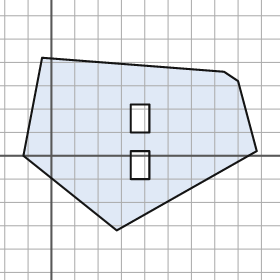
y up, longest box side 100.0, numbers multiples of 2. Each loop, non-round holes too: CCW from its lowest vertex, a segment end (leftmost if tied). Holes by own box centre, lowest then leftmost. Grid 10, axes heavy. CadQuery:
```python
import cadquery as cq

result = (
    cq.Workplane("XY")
    .moveTo(28.0, -32.0)
    .lineTo(88.0, 2.0)
    .lineTo(80.0, 32.0)
    .lineTo(74.0, 36.0)
    .lineTo(-4.0, 42.0)
    .lineTo(-12.0, 0.0)
    .close()
    .moveTo(34.0, -10.0)
    .lineTo(42.0, -10.0)
    .lineTo(42.0, 2.0)
    .lineTo(34.0, 2.0)
    .close()
    .moveTo(34.0, 10.0)
    .lineTo(42.0, 10.0)
    .lineTo(42.0, 22.0)
    .lineTo(34.0, 22.0)
    .close()
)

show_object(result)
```